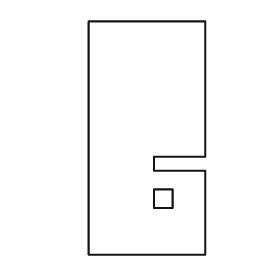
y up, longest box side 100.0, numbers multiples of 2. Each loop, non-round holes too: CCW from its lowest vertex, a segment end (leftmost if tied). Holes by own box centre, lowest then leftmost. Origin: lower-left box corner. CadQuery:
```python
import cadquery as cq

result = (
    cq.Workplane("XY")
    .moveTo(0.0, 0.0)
    .lineTo(50.0, 0.0)
    .lineTo(50.0, 36.0)
    .lineTo(28.0, 36.0)
    .lineTo(28.0, 42.0)
    .lineTo(50.0, 42.0)
    .lineTo(50.0, 100.0)
    .lineTo(0.0, 100.0)
    .close()
    .moveTo(28.0, 20.0)
    .lineTo(36.0, 20.0)
    .lineTo(36.0, 28.0)
    .lineTo(28.0, 28.0)
    .close()
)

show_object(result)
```